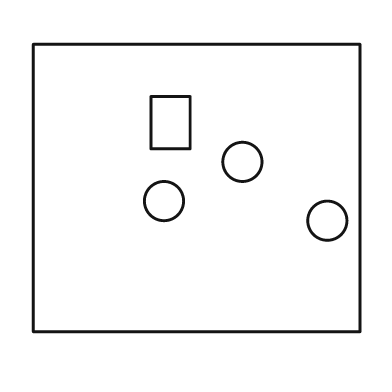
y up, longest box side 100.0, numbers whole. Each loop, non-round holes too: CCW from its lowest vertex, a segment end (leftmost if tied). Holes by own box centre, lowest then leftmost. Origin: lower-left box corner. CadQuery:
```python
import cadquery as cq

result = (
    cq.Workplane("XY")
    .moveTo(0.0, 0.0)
    .lineTo(100.0, 0.0)
    .lineTo(100.0, 88.0)
    .lineTo(0.0, 88.0)
    .close()
    .moveTo(90.0, 34.0)
    .circle(6.0)
    .moveTo(40.0, 40.0)
    .circle(6.0)
    .moveTo(64.0, 52.0)
    .circle(6.0)
    .moveTo(36.0, 56.0)
    .lineTo(48.0, 56.0)
    .lineTo(48.0, 72.0)
    .lineTo(36.0, 72.0)
    .close()
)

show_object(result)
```